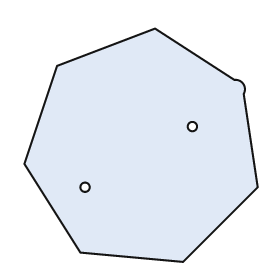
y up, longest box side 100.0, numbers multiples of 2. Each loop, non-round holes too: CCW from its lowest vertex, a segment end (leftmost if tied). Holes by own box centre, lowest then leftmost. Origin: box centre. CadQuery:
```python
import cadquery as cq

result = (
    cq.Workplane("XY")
    .moveTo(18.0, -50.0)
    .lineTo(50.0, -18.0)
    .lineTo(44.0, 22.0)
    .threePointArc((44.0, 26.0), (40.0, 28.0))
    .lineTo(6.0, 50.0)
    .lineTo(-36.0, 34.0)
    .lineTo(-50.0, -8.0)
    .lineTo(-26.0, -46.0)
    .close()
    .moveTo(-24.0, -18.0)
    .circle(2.0)
    .moveTo(22.0, 8.0)
    .circle(2.0)
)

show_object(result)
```